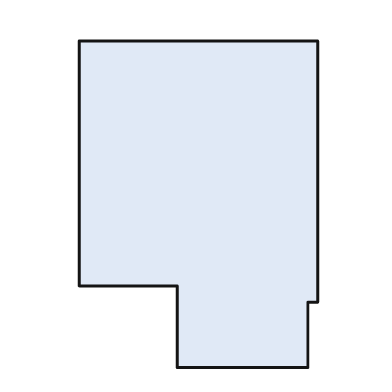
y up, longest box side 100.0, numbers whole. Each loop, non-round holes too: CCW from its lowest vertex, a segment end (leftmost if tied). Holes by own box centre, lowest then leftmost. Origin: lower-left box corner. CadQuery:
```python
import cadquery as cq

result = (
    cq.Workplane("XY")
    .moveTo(30.0, 0.0)
    .lineTo(70.0, 0.0)
    .lineTo(70.0, 20.0)
    .lineTo(73.0, 20.0)
    .lineTo(73.0, 100.0)
    .lineTo(0.0, 100.0)
    .lineTo(0.0, 25.0)
    .lineTo(30.0, 25.0)
    .close()
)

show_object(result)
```